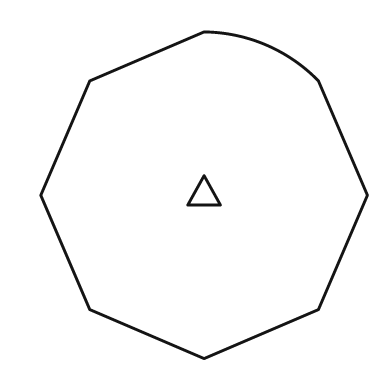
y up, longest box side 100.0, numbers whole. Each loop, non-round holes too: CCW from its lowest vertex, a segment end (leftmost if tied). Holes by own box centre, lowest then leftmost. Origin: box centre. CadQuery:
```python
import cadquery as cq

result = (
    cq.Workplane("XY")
    .moveTo(0.0, -50.0)
    .lineTo(35.0, -35.0)
    .lineTo(50.0, 0.0)
    .lineTo(35.0, 35.0)
    .threePointArc((19.0, 46.0), (0.0, 50.0))
    .lineTo(-35.0, 35.0)
    .lineTo(-50.0, 0.0)
    .lineTo(-35.0, -35.0)
    .close()
    .moveTo(-5.0, -3.0)
    .lineTo(5.0, -3.0)
    .lineTo(0.0, 6.0)
    .close()
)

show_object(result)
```